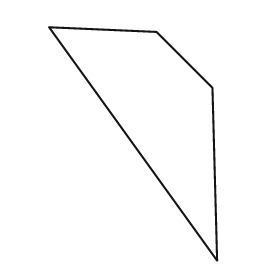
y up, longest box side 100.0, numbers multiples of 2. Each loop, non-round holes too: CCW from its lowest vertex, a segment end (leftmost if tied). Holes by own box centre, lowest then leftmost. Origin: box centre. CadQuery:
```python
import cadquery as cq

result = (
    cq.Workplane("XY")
    .moveTo(36.0, -50.0)
    .lineTo(34.0, 24.0)
    .lineTo(10.0, 48.0)
    .lineTo(-36.0, 50.0)
    .close()
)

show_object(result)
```